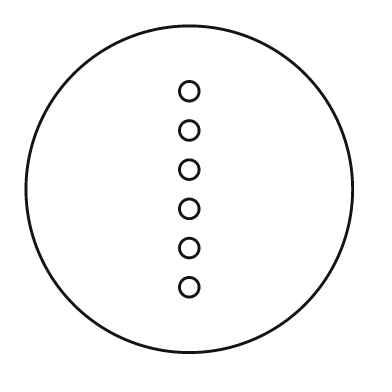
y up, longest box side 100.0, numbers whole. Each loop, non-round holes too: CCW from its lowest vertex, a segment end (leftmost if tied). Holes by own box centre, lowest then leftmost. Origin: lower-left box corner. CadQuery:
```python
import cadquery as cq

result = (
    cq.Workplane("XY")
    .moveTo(50.0, 50.0)
    .circle(50.0)
    .moveTo(50.0, 20.0)
    .circle(3.0)
    .moveTo(50.0, 32.0)
    .circle(3.0)
    .moveTo(50.0, 44.0)
    .circle(3.0)
    .moveTo(50.0, 56.0)
    .circle(3.0)
    .moveTo(50.0, 68.0)
    .circle(3.0)
    .moveTo(50.0, 80.0)
    .circle(3.0)
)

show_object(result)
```